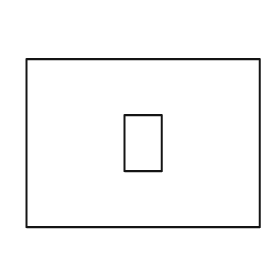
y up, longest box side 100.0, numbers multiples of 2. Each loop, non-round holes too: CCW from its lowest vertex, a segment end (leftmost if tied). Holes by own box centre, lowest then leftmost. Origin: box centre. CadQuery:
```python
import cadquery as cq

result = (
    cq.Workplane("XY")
    .moveTo(-50.0, -36.0)
    .lineTo(50.0, -36.0)
    .lineTo(50.0, 36.0)
    .lineTo(-50.0, 36.0)
    .close()
    .moveTo(-8.0, -12.0)
    .lineTo(8.0, -12.0)
    .lineTo(8.0, 12.0)
    .lineTo(-8.0, 12.0)
    .close()
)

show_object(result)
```